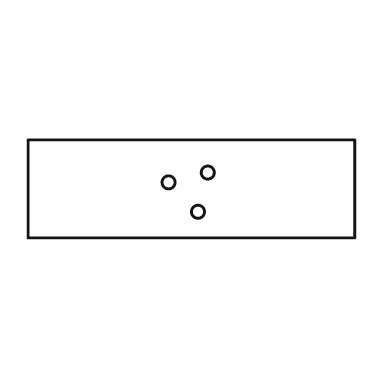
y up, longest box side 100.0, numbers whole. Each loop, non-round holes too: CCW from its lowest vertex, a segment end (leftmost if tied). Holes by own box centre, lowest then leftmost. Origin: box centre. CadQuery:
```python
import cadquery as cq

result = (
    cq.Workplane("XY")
    .moveTo(-50.0, -15.0)
    .lineTo(50.0, -15.0)
    .lineTo(50.0, 15.0)
    .lineTo(-50.0, 15.0)
    .close()
    .moveTo(2.0, -7.0)
    .circle(2.0)
    .moveTo(-7.0, 2.0)
    .circle(2.0)
    .moveTo(5.0, 5.0)
    .circle(2.0)
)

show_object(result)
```